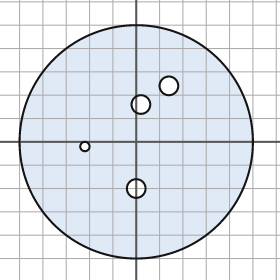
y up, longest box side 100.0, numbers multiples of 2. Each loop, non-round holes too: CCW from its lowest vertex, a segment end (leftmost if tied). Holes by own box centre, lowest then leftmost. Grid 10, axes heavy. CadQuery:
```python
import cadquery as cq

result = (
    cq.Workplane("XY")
    .moveTo(0.0, 0.0)
    .circle(50.0)
    .moveTo(0.0, -20.0)
    .circle(4.0)
    .moveTo(-22.0, -2.0)
    .circle(2.0)
    .moveTo(2.0, 16.0)
    .circle(4.0)
    .moveTo(14.0, 24.0)
    .circle(4.0)
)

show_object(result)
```